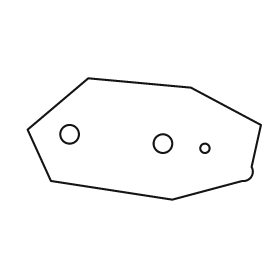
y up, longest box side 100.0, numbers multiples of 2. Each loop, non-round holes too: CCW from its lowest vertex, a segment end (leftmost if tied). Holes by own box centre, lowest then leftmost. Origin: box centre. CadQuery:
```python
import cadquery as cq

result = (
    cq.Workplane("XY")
    .moveTo(12.0, -26.0)
    .lineTo(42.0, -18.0)
    .threePointArc((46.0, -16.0), (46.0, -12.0))
    .lineTo(50.0, 6.0)
    .lineTo(20.0, 22.0)
    .lineTo(-24.0, 26.0)
    .lineTo(-50.0, 4.0)
    .lineTo(-40.0, -18.0)
    .close()
    .moveTo(26.0, -4.0)
    .circle(2.0)
    .moveTo(8.0, -2.0)
    .circle(4.0)
    .moveTo(-32.0, 2.0)
    .circle(4.0)
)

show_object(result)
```